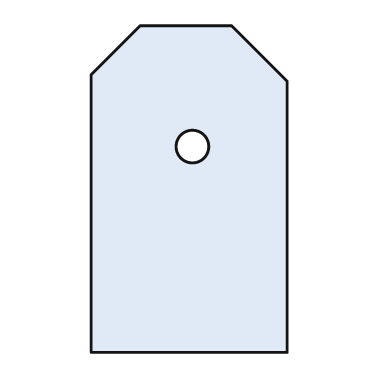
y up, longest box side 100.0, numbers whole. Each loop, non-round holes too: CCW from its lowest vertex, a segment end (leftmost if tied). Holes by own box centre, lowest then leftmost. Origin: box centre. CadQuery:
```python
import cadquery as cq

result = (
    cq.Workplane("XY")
    .moveTo(-30.0, -50.0)
    .lineTo(30.0, -50.0)
    .lineTo(30.0, 33.0)
    .lineTo(13.0, 50.0)
    .lineTo(-15.0, 50.0)
    .lineTo(-30.0, 35.0)
    .close()
    .moveTo(1.0, 13.0)
    .circle(5.0)
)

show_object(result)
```